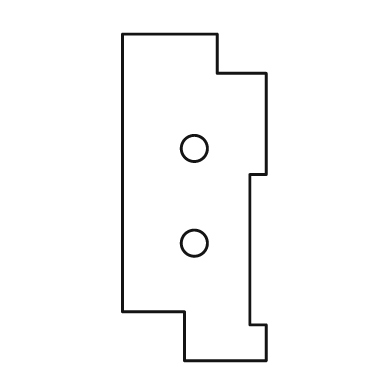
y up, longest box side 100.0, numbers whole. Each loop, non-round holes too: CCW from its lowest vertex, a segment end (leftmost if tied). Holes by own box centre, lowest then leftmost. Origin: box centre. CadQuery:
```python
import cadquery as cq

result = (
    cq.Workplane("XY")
    .moveTo(-3.0, -50.0)
    .lineTo(22.0, -50.0)
    .lineTo(22.0, -39.0)
    .lineTo(17.0, -39.0)
    .lineTo(17.0, 7.0)
    .lineTo(22.0, 7.0)
    .lineTo(22.0, 38.0)
    .lineTo(7.0, 38.0)
    .lineTo(7.0, 50.0)
    .lineTo(-22.0, 50.0)
    .lineTo(-22.0, -35.0)
    .lineTo(-3.0, -35.0)
    .close()
    .moveTo(0.0, -14.0)
    .circle(4.0)
    .moveTo(0.0, 15.0)
    .circle(4.0)
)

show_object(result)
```